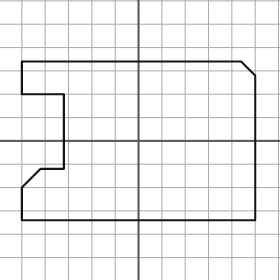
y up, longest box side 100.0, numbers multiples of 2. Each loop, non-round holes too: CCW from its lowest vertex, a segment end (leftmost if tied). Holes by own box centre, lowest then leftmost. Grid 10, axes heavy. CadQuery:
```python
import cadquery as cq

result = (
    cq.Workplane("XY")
    .moveTo(-50.0, -34.0)
    .lineTo(50.0, -34.0)
    .lineTo(50.0, 28.0)
    .lineTo(44.0, 34.0)
    .lineTo(-50.0, 34.0)
    .lineTo(-50.0, 20.0)
    .lineTo(-32.0, 20.0)
    .lineTo(-32.0, -12.0)
    .lineTo(-42.0, -12.0)
    .lineTo(-50.0, -20.0)
    .close()
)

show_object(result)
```